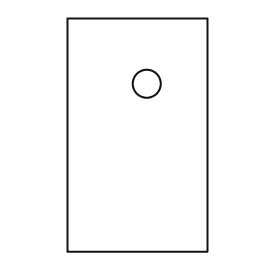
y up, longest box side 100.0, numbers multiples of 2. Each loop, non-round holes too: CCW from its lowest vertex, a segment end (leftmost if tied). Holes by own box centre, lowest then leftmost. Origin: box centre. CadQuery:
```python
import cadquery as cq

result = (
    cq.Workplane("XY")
    .moveTo(-30.0, -50.0)
    .lineTo(30.0, -50.0)
    .lineTo(30.0, 50.0)
    .lineTo(-30.0, 50.0)
    .close()
    .moveTo(4.0, 22.0)
    .circle(6.0)
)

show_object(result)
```